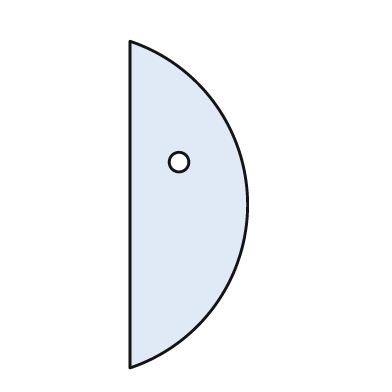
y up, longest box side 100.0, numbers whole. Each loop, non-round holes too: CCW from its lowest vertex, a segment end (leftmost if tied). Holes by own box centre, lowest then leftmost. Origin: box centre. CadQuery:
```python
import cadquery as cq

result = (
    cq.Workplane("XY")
    .moveTo(-18.0, -50.0)
    .threePointArc((18.0, 0.0), (-18.0, 50.0))
    .close()
    .moveTo(-3.0, 13.0)
    .circle(3.0)
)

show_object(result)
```